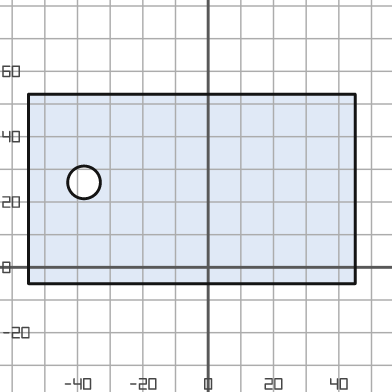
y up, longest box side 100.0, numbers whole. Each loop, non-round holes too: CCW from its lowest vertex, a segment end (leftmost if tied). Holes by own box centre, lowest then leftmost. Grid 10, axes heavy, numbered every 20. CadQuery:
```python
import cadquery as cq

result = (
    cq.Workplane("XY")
    .moveTo(-55.0, -5.0)
    .lineTo(45.0, -5.0)
    .lineTo(45.0, 53.0)
    .lineTo(-55.0, 53.0)
    .close()
    .moveTo(-38.0, 26.0)
    .circle(5.0)
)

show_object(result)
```